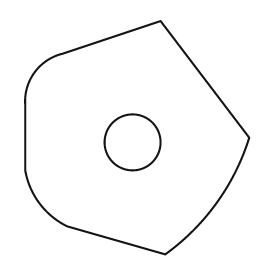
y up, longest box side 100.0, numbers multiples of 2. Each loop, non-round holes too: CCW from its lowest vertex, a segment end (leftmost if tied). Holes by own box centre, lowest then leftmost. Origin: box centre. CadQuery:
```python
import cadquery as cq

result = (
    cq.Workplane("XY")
    .moveTo(12.0, -50.0)
    .threePointArc((34.0, -28.0), (48.0, 0.0))
    .lineTo(10.0, 50.0)
    .lineTo(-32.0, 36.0)
    .threePointArc((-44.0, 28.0), (-48.0, 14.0))
    .lineTo(-48.0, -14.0)
    .threePointArc((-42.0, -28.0), (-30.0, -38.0))
    .close()
    .moveTo(-2.0, -2.0)
    .circle(12.0)
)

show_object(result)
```